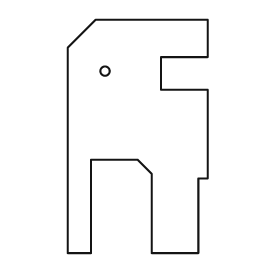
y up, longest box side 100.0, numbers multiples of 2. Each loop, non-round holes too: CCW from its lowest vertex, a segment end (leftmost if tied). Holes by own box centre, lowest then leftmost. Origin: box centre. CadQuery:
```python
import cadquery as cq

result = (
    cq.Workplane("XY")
    .moveTo(-30.0, -50.0)
    .lineTo(-20.0, -50.0)
    .lineTo(-20.0, -10.0)
    .lineTo(0.0, -10.0)
    .lineTo(6.0, -16.0)
    .lineTo(6.0, -50.0)
    .lineTo(26.0, -50.0)
    .lineTo(26.0, -18.0)
    .lineTo(30.0, -18.0)
    .lineTo(30.0, 20.0)
    .lineTo(10.0, 20.0)
    .lineTo(10.0, 34.0)
    .lineTo(30.0, 34.0)
    .lineTo(30.0, 50.0)
    .lineTo(-18.0, 50.0)
    .lineTo(-30.0, 38.0)
    .close()
    .moveTo(-14.0, 28.0)
    .circle(2.0)
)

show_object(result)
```